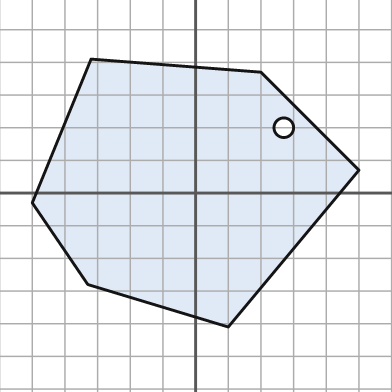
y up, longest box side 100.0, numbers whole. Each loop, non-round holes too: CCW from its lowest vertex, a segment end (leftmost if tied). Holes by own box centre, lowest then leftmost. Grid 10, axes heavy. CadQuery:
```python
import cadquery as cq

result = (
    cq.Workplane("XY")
    .moveTo(10.0, -41.0)
    .lineTo(50.0, 7.0)
    .lineTo(20.0, 37.0)
    .lineTo(-32.0, 41.0)
    .lineTo(-50.0, -3.0)
    .lineTo(-33.0, -28.0)
    .close()
    .moveTo(27.0, 20.0)
    .circle(3.0)
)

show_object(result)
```